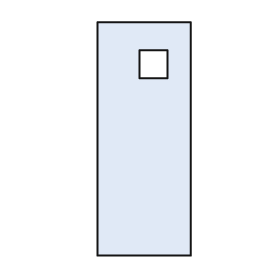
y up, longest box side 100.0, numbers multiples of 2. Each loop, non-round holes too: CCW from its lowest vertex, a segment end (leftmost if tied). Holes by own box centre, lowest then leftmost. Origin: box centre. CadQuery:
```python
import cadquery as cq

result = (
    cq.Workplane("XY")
    .moveTo(-20.0, -50.0)
    .lineTo(20.0, -50.0)
    .lineTo(20.0, 50.0)
    .lineTo(-20.0, 50.0)
    .close()
    .moveTo(-2.0, 26.0)
    .lineTo(10.0, 26.0)
    .lineTo(10.0, 38.0)
    .lineTo(-2.0, 38.0)
    .close()
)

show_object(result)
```